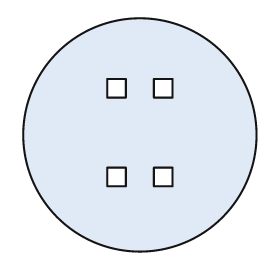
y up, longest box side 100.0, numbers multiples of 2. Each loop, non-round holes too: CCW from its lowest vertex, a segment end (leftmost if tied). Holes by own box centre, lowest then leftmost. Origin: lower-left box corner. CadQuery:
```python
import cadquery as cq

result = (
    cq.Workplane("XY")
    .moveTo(50.0, 50.0)
    .circle(50.0)
    .moveTo(36.0, 28.0)
    .lineTo(44.0, 28.0)
    .lineTo(44.0, 36.0)
    .lineTo(36.0, 36.0)
    .close()
    .moveTo(56.0, 28.0)
    .lineTo(64.0, 28.0)
    .lineTo(64.0, 36.0)
    .lineTo(56.0, 36.0)
    .close()
    .moveTo(36.0, 66.0)
    .lineTo(44.0, 66.0)
    .lineTo(44.0, 74.0)
    .lineTo(36.0, 74.0)
    .close()
    .moveTo(56.0, 66.0)
    .lineTo(64.0, 66.0)
    .lineTo(64.0, 74.0)
    .lineTo(56.0, 74.0)
    .close()
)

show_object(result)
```